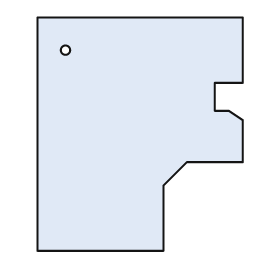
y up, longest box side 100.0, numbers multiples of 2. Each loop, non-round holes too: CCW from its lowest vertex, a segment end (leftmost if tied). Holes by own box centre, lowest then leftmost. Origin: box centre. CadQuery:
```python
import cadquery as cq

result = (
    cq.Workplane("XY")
    .moveTo(-44.0, -50.0)
    .lineTo(10.0, -50.0)
    .lineTo(10.0, -22.0)
    .lineTo(20.0, -12.0)
    .lineTo(44.0, -12.0)
    .lineTo(44.0, 6.0)
    .lineTo(38.0, 10.0)
    .lineTo(32.0, 10.0)
    .lineTo(32.0, 22.0)
    .lineTo(44.0, 22.0)
    .lineTo(44.0, 50.0)
    .lineTo(-44.0, 50.0)
    .close()
    .moveTo(-32.0, 36.0)
    .circle(2.0)
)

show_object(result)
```